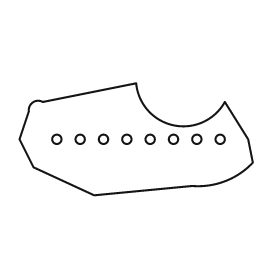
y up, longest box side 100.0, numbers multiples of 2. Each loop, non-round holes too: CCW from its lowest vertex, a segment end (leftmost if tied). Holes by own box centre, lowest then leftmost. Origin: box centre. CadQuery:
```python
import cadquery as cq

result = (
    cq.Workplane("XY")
    .moveTo(-18.0, -24.0)
    .lineTo(24.0, -20.0)
    .threePointArc((38.0, -18.0), (50.0, -10.0))
    .lineTo(48.0, 0.0)
    .lineTo(38.0, 16.0)
    .threePointArc((16.0, 6.0), (0.0, 24.0))
    .lineTo(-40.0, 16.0)
    .threePointArc((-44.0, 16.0), (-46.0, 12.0))
    .lineTo(-50.0, 0.0)
    .lineTo(-44.0, -12.0)
    .close()
    .moveTo(-34.0, 0.0)
    .circle(2.0)
    .moveTo(-24.0, 0.0)
    .circle(2.0)
    .moveTo(-14.0, 0.0)
    .circle(2.0)
    .moveTo(-4.0, 0.0)
    .circle(2.0)
    .moveTo(6.0, 0.0)
    .circle(2.0)
    .moveTo(16.0, 0.0)
    .circle(2.0)
    .moveTo(26.0, 0.0)
    .circle(2.0)
    .moveTo(36.0, 0.0)
    .circle(2.0)
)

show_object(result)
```